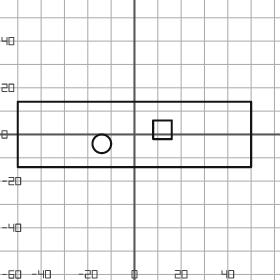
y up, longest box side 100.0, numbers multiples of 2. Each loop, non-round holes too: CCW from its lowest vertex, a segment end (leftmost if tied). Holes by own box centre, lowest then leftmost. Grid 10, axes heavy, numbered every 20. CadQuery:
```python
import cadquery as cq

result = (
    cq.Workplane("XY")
    .moveTo(-50.0, -14.0)
    .lineTo(50.0, -14.0)
    .lineTo(50.0, 14.0)
    .lineTo(-50.0, 14.0)
    .close()
    .moveTo(-14.0, -4.0)
    .circle(4.0)
    .moveTo(8.0, -2.0)
    .lineTo(16.0, -2.0)
    .lineTo(16.0, 6.0)
    .lineTo(8.0, 6.0)
    .close()
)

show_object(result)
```